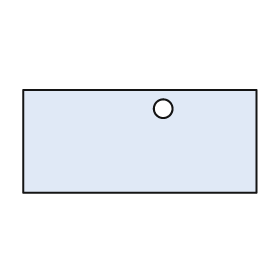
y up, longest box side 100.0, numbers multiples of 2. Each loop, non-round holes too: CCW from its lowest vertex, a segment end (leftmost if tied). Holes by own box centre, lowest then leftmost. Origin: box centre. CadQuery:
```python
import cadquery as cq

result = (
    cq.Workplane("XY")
    .moveTo(-50.0, -22.0)
    .lineTo(50.0, -22.0)
    .lineTo(50.0, 22.0)
    .lineTo(-50.0, 22.0)
    .close()
    .moveTo(10.0, 14.0)
    .circle(4.0)
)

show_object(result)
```